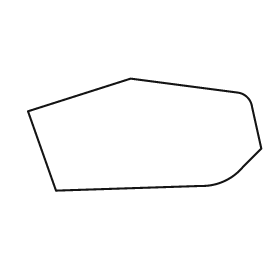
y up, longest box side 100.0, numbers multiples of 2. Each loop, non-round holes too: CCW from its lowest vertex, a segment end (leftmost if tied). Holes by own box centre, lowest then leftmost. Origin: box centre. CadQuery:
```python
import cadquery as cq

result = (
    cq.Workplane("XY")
    .moveTo(-38.0, -24.0)
    .lineTo(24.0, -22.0)
    .threePointArc((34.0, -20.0), (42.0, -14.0))
    .lineTo(50.0, -6.0)
    .lineTo(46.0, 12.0)
    .threePointArc((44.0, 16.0), (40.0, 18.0))
    .lineTo(-6.0, 24.0)
    .lineTo(-50.0, 10.0)
    .close()
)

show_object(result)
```